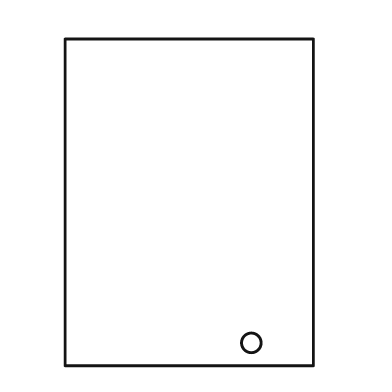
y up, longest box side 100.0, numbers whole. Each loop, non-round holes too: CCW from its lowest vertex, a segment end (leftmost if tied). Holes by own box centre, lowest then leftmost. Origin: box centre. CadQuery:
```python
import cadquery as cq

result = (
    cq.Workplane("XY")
    .moveTo(-38.0, -50.0)
    .lineTo(38.0, -50.0)
    .lineTo(38.0, 50.0)
    .lineTo(-38.0, 50.0)
    .close()
    .moveTo(19.0, -43.0)
    .circle(3.0)
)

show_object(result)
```